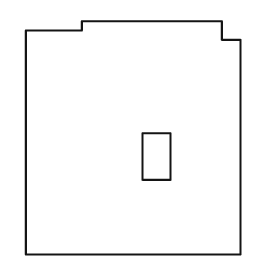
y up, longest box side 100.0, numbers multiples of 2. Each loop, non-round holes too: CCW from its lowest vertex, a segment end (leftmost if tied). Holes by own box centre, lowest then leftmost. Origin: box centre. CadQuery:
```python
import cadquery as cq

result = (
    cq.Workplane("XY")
    .moveTo(-46.0, -50.0)
    .lineTo(46.0, -50.0)
    .lineTo(46.0, 42.0)
    .lineTo(38.0, 42.0)
    .lineTo(38.0, 50.0)
    .lineTo(-22.0, 50.0)
    .lineTo(-22.0, 46.0)
    .lineTo(-46.0, 46.0)
    .close()
    .moveTo(4.0, -18.0)
    .lineTo(16.0, -18.0)
    .lineTo(16.0, 2.0)
    .lineTo(4.0, 2.0)
    .close()
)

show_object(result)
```